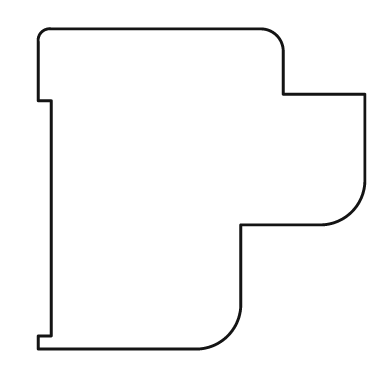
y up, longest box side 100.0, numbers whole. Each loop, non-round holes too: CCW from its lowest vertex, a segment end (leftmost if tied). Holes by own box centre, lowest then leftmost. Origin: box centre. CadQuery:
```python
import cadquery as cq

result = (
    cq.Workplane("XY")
    .moveTo(-50.0, -49.0)
    .lineTo(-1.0, -49.0)
    .threePointArc((8.0, -45.0), (12.0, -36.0))
    .lineTo(12.0, -11.0)
    .lineTo(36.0, -11.0)
    .threePointArc((46.0, -7.0), (50.0, 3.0))
    .lineTo(50.0, 29.0)
    .lineTo(25.0, 29.0)
    .lineTo(25.0, 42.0)
    .threePointArc((23.0, 47.0), (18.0, 49.0))
    .lineTo(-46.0, 49.0)
    .threePointArc((-49.0, 48.0), (-50.0, 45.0))
    .lineTo(-50.0, 27.0)
    .lineTo(-46.0, 27.0)
    .lineTo(-46.0, -45.0)
    .lineTo(-50.0, -45.0)
    .close()
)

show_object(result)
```